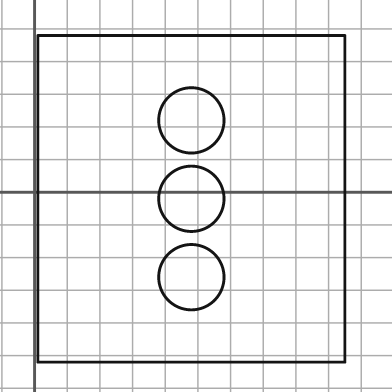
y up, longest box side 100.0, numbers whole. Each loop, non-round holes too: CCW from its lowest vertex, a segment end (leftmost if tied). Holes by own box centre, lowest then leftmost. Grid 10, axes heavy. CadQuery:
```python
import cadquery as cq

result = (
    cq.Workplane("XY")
    .moveTo(1.0, -52.0)
    .lineTo(95.0, -52.0)
    .lineTo(95.0, 48.0)
    .lineTo(1.0, 48.0)
    .close()
    .moveTo(48.0, -26.0)
    .circle(10.0)
    .moveTo(48.0, -2.0)
    .circle(10.0)
    .moveTo(48.0, 22.0)
    .circle(10.0)
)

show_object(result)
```